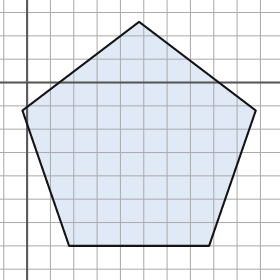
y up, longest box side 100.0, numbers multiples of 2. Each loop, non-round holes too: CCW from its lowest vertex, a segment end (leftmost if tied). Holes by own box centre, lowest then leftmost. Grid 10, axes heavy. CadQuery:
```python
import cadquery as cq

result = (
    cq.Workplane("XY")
    .moveTo(18.0, -70.0)
    .lineTo(78.0, -70.0)
    .lineTo(98.0, -12.0)
    .lineTo(48.0, 26.0)
    .lineTo(-2.0, -12.0)
    .close()
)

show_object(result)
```